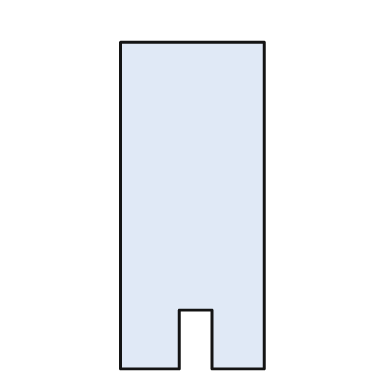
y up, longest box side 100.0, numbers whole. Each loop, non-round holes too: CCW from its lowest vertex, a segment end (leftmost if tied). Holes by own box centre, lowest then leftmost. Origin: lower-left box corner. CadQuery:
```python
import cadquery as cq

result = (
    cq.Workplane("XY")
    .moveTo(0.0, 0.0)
    .lineTo(18.0, 0.0)
    .lineTo(18.0, 18.0)
    .lineTo(28.0, 18.0)
    .lineTo(28.0, 0.0)
    .lineTo(44.0, 0.0)
    .lineTo(44.0, 100.0)
    .lineTo(0.0, 100.0)
    .close()
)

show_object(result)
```